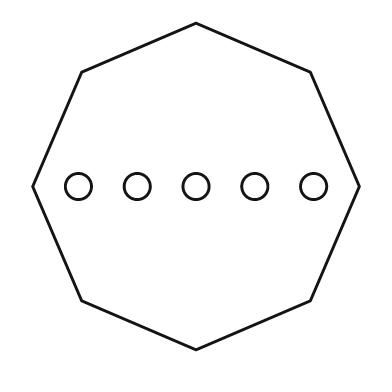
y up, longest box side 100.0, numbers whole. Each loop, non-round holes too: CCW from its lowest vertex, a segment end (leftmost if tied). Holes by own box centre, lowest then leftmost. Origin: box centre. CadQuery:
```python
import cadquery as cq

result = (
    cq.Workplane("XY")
    .moveTo(0.0, -50.0)
    .lineTo(35.0, -35.0)
    .lineTo(50.0, 0.0)
    .lineTo(35.0, 35.0)
    .lineTo(0.0, 50.0)
    .lineTo(-35.0, 35.0)
    .lineTo(-50.0, 0.0)
    .lineTo(-35.0, -35.0)
    .close()
    .moveTo(-36.0, 0.0)
    .circle(4.0)
    .moveTo(-18.0, 0.0)
    .circle(4.0)
    .moveTo(0.0, 0.0)
    .circle(4.0)
    .moveTo(18.0, 0.0)
    .circle(4.0)
    .moveTo(36.0, 0.0)
    .circle(4.0)
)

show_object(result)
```